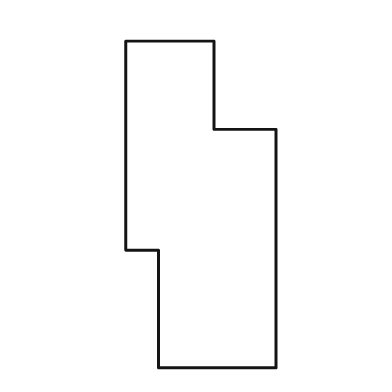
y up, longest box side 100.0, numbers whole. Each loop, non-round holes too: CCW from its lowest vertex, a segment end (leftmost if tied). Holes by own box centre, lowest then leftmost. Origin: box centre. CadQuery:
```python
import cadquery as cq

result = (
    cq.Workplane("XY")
    .moveTo(-13.0, -50.0)
    .lineTo(23.0, -50.0)
    .lineTo(23.0, 23.0)
    .lineTo(4.0, 23.0)
    .lineTo(4.0, 50.0)
    .lineTo(-23.0, 50.0)
    .lineTo(-23.0, -14.0)
    .lineTo(-13.0, -14.0)
    .close()
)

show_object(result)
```